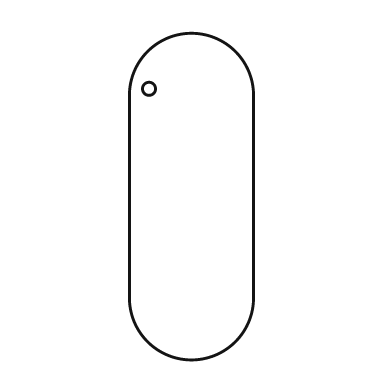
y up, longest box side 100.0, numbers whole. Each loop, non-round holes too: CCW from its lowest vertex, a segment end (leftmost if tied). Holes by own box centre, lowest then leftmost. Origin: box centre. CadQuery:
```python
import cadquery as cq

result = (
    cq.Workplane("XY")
    .moveTo(-19.0, -31.0)
    .threePointArc((0.0, -50.0), (19.0, -31.0))
    .lineTo(19.0, 31.0)
    .threePointArc((0.0, 50.0), (-19.0, 31.0))
    .close()
    .moveTo(-13.0, 33.0)
    .circle(2.0)
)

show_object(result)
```